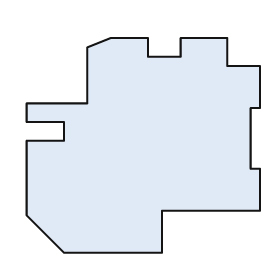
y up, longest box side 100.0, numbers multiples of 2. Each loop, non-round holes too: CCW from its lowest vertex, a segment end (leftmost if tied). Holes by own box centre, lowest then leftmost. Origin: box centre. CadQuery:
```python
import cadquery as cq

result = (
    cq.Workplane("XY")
    .moveTo(-34.0, -46.0)
    .lineTo(8.0, -46.0)
    .lineTo(8.0, -28.0)
    .lineTo(50.0, -28.0)
    .lineTo(50.0, -10.0)
    .lineTo(46.0, -10.0)
    .lineTo(46.0, 16.0)
    .lineTo(50.0, 16.0)
    .lineTo(50.0, 34.0)
    .lineTo(36.0, 34.0)
    .lineTo(36.0, 46.0)
    .lineTo(16.0, 46.0)
    .lineTo(16.0, 38.0)
    .lineTo(2.0, 38.0)
    .lineTo(2.0, 46.0)
    .lineTo(-14.0, 46.0)
    .lineTo(-24.0, 42.0)
    .lineTo(-24.0, 18.0)
    .lineTo(-50.0, 18.0)
    .lineTo(-50.0, 10.0)
    .lineTo(-34.0, 10.0)
    .lineTo(-34.0, 2.0)
    .lineTo(-50.0, 2.0)
    .lineTo(-50.0, -30.0)
    .close()
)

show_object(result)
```